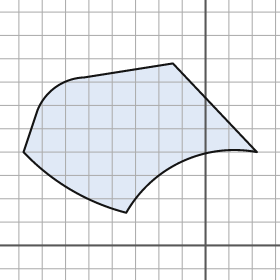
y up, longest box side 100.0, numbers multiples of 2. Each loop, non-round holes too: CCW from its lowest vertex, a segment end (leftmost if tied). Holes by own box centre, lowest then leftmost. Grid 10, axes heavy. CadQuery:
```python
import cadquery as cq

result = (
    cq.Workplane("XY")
    .moveTo(-34.0, 14.0)
    .threePointArc((-10.0, 36.0), (22.0, 40.0))
    .lineTo(-14.0, 78.0)
    .lineTo(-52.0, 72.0)
    .threePointArc((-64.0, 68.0), (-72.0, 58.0))
    .lineTo(-78.0, 40.0)
    .threePointArc((-58.0, 24.0), (-34.0, 14.0))
    .close()
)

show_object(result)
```